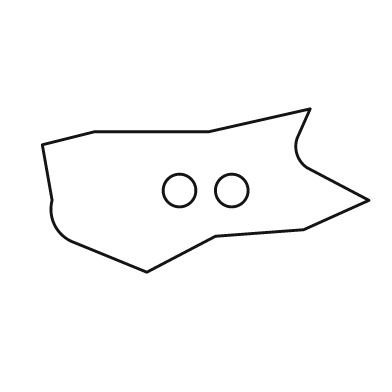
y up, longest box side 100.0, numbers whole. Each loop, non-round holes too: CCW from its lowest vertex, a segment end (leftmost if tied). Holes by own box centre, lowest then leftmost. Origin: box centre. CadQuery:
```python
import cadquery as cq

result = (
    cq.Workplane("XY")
    .moveTo(-18.0, -25.0)
    .lineTo(3.0, -14.0)
    .lineTo(30.0, -12.0)
    .lineTo(50.0, -3.0)
    .lineTo(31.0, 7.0)
    .threePointArc((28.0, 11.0), (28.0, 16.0))
    .lineTo(32.0, 25.0)
    .lineTo(1.0, 18.0)
    .lineTo(-34.0, 18.0)
    .lineTo(-50.0, 14.0)
    .lineTo(-47.0, -3.0)
    .threePointArc((-46.0, -11.0), (-40.0, -16.0))
    .close()
    .moveTo(-8.0, 0.0)
    .circle(5.0)
    .moveTo(8.0, 0.0)
    .circle(5.0)
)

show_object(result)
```